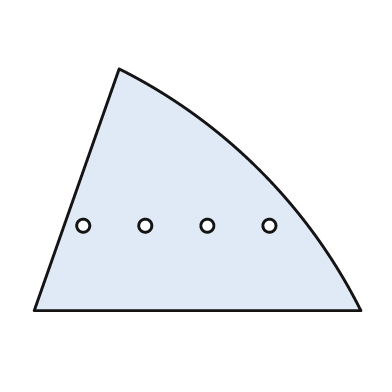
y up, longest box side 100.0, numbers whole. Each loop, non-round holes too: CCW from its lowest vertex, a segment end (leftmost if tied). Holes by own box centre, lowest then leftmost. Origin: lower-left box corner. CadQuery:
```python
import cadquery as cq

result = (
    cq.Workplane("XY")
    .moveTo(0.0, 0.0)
    .lineTo(100.0, 0.0)
    .threePointArc((69.0, 43.0), (26.0, 74.0))
    .close()
    .moveTo(15.0, 26.0)
    .circle(2.0)
    .moveTo(34.0, 26.0)
    .circle(2.0)
    .moveTo(53.0, 26.0)
    .circle(2.0)
    .moveTo(72.0, 26.0)
    .circle(2.0)
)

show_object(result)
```